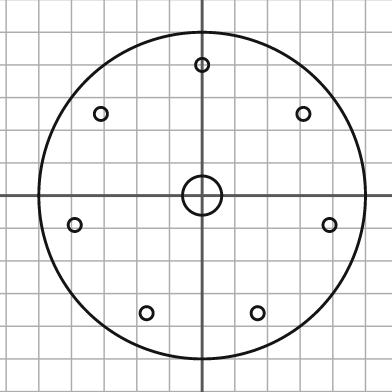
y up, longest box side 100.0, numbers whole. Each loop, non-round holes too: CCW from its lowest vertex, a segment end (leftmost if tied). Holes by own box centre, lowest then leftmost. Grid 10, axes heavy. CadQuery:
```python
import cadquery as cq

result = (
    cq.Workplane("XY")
    .moveTo(0.0, 0.0)
    .circle(50.0)
    .moveTo(-17.0, -36.0)
    .circle(2.0)
    .moveTo(17.0, -36.0)
    .circle(2.0)
    .moveTo(-39.0, -9.0)
    .circle(2.0)
    .moveTo(39.0, -9.0)
    .circle(2.0)
    .moveTo(0.0, 0.0)
    .circle(6.0)
    .moveTo(-31.0, 25.0)
    .circle(2.0)
    .moveTo(31.0, 25.0)
    .circle(2.0)
    .moveTo(0.0, 40.0)
    .circle(2.0)
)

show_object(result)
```